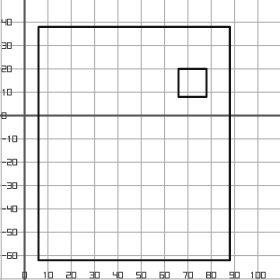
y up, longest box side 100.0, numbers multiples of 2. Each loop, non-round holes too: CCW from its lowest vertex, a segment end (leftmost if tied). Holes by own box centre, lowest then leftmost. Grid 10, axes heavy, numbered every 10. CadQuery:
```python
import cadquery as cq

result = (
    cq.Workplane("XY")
    .moveTo(6.0, -62.0)
    .lineTo(88.0, -62.0)
    .lineTo(88.0, 38.0)
    .lineTo(6.0, 38.0)
    .close()
    .moveTo(66.0, 8.0)
    .lineTo(78.0, 8.0)
    .lineTo(78.0, 20.0)
    .lineTo(66.0, 20.0)
    .close()
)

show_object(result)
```